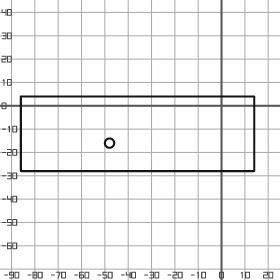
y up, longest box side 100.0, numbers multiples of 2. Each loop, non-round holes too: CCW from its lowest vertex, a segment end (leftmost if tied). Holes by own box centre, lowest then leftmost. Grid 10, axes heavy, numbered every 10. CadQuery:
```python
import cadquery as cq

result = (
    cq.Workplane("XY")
    .moveTo(-86.0, -28.0)
    .lineTo(14.0, -28.0)
    .lineTo(14.0, 4.0)
    .lineTo(-86.0, 4.0)
    .close()
    .moveTo(-48.0, -16.0)
    .circle(2.0)
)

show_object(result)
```